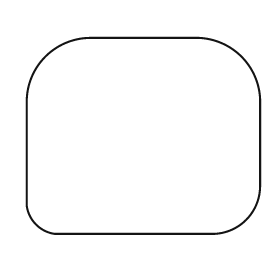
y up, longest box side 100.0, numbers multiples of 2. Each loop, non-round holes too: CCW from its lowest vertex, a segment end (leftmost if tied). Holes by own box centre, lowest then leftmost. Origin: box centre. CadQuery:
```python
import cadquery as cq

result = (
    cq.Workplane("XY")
    .moveTo(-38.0, -42.0)
    .lineTo(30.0, -42.0)
    .threePointArc((44.0, -36.0), (50.0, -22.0))
    .lineTo(50.0, 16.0)
    .threePointArc((42.0, 34.0), (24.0, 42.0))
    .lineTo(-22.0, 42.0)
    .threePointArc((-42.0, 34.0), (-50.0, 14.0))
    .lineTo(-50.0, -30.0)
    .threePointArc((-46.0, -38.0), (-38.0, -42.0))
    .close()
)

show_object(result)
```